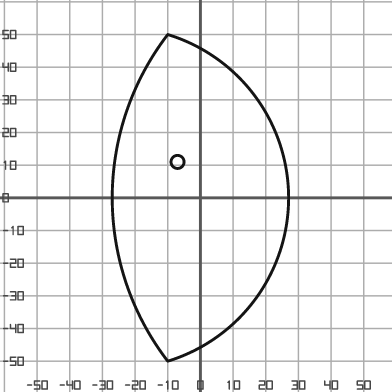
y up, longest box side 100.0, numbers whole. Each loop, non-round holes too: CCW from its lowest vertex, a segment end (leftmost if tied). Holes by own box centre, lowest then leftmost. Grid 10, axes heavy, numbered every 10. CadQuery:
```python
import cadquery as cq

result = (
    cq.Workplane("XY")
    .moveTo(-10.0, -50.0)
    .threePointArc((27.0, 0.0), (-10.0, 50.0))
    .threePointArc((-27.0, 0.0), (-10.0, -50.0))
    .close()
    .moveTo(-7.0, 11.0)
    .circle(2.0)
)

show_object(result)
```